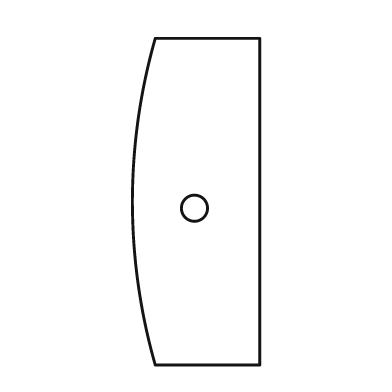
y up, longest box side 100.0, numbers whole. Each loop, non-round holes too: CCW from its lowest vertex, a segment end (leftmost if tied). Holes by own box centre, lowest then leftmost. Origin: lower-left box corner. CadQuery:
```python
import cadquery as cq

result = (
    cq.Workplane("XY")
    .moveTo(7.0, 0.0)
    .lineTo(39.0, 0.0)
    .lineTo(39.0, 100.0)
    .lineTo(7.0, 100.0)
    .threePointArc((0.0, 50.0), (7.0, 0.0))
    .close()
    .moveTo(19.0, 48.0)
    .circle(4.0)
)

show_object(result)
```